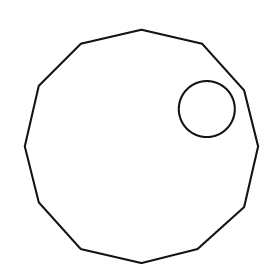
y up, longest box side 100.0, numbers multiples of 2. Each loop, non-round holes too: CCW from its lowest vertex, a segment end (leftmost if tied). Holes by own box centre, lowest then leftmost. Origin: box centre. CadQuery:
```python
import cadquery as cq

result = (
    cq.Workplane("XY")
    .moveTo(0.0, -50.0)
    .lineTo(24.0, -44.0)
    .lineTo(44.0, -26.0)
    .lineTo(50.0, 0.0)
    .lineTo(44.0, 24.0)
    .lineTo(26.0, 44.0)
    .lineTo(0.0, 50.0)
    .lineTo(-26.0, 44.0)
    .lineTo(-44.0, 26.0)
    .lineTo(-50.0, 0.0)
    .lineTo(-44.0, -24.0)
    .lineTo(-26.0, -44.0)
    .close()
    .moveTo(28.0, 16.0)
    .circle(12.0)
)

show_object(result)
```